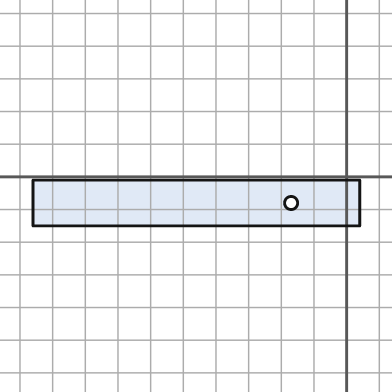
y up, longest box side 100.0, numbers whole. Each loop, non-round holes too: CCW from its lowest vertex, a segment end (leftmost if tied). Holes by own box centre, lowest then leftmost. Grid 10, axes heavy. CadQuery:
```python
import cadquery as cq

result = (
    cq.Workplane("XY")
    .moveTo(-96.0, -15.0)
    .lineTo(4.0, -15.0)
    .lineTo(4.0, -1.0)
    .lineTo(-96.0, -1.0)
    .close()
    .moveTo(-17.0, -8.0)
    .circle(2.0)
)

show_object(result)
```